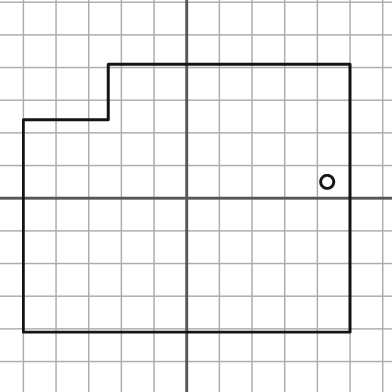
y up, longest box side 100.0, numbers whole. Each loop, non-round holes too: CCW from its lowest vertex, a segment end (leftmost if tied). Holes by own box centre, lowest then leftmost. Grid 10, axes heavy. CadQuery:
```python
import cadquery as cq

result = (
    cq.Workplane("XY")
    .moveTo(-50.0, -41.0)
    .lineTo(50.0, -41.0)
    .lineTo(50.0, 41.0)
    .lineTo(-24.0, 41.0)
    .lineTo(-24.0, 24.0)
    .lineTo(-50.0, 24.0)
    .close()
    .moveTo(43.0, 5.0)
    .circle(2.0)
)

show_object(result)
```